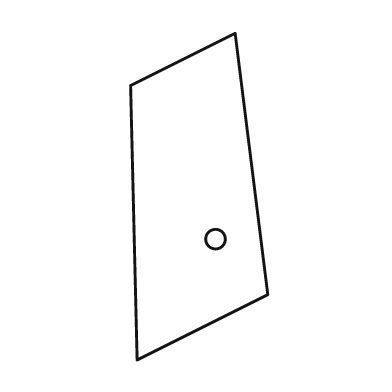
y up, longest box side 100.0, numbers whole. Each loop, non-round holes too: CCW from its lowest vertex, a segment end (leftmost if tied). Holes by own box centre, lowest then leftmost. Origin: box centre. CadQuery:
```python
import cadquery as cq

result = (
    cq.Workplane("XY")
    .moveTo(-19.0, -50.0)
    .lineTo(21.0, -30.0)
    .lineTo(11.0, 50.0)
    .lineTo(-21.0, 34.0)
    .close()
    .moveTo(5.0, -13.0)
    .circle(3.0)
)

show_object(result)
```